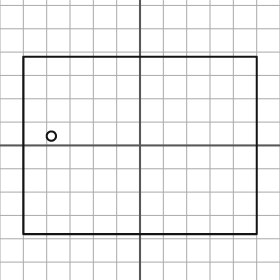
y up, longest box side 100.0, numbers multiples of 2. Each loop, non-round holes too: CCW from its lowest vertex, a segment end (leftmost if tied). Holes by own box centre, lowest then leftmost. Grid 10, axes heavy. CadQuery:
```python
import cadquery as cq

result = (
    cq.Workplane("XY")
    .moveTo(-50.0, -38.0)
    .lineTo(50.0, -38.0)
    .lineTo(50.0, 38.0)
    .lineTo(-50.0, 38.0)
    .close()
    .moveTo(-38.0, 4.0)
    .circle(2.0)
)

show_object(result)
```